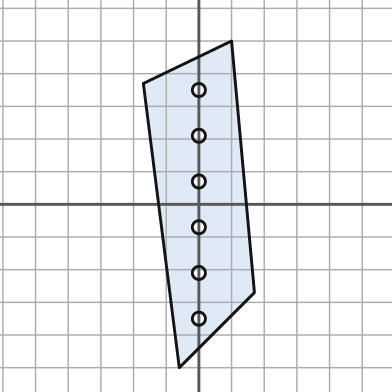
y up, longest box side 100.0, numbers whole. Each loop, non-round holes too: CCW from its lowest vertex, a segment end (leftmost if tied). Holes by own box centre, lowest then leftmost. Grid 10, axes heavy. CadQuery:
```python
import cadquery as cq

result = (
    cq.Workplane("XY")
    .moveTo(-6.0, -50.0)
    .lineTo(17.0, -27.0)
    .lineTo(10.0, 50.0)
    .lineTo(-17.0, 37.0)
    .close()
    .moveTo(0.0, -35.0)
    .circle(2.0)
    .moveTo(0.0, -21.0)
    .circle(2.0)
    .moveTo(0.0, -7.0)
    .circle(2.0)
    .moveTo(0.0, 7.0)
    .circle(2.0)
    .moveTo(0.0, 21.0)
    .circle(2.0)
    .moveTo(0.0, 35.0)
    .circle(2.0)
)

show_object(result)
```